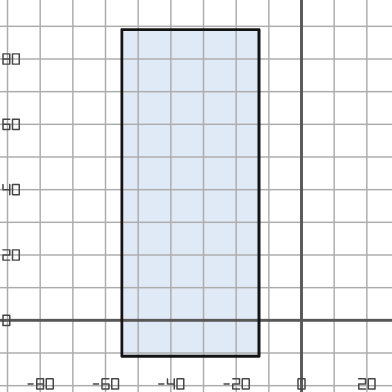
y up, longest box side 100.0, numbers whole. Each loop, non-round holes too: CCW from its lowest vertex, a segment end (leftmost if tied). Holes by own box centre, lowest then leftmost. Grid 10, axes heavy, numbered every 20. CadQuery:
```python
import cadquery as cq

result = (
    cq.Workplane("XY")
    .moveTo(-55.0, -11.0)
    .lineTo(-13.0, -11.0)
    .lineTo(-13.0, 89.0)
    .lineTo(-55.0, 89.0)
    .close()
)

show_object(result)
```